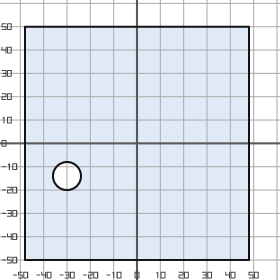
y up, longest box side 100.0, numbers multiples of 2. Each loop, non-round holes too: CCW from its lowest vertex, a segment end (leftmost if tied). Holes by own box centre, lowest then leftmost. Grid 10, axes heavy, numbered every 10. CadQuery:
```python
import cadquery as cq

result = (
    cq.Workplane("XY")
    .moveTo(-48.0, -50.0)
    .lineTo(48.0, -50.0)
    .lineTo(48.0, 50.0)
    .lineTo(-48.0, 50.0)
    .close()
    .moveTo(-30.0, -14.0)
    .circle(6.0)
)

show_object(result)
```